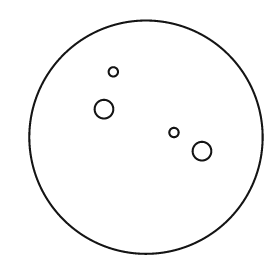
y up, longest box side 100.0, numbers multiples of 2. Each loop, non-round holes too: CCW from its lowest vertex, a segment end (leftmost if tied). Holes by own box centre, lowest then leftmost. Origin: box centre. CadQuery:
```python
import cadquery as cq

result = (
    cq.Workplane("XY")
    .moveTo(0.0, 0.0)
    .circle(50.0)
    .moveTo(24.0, -6.0)
    .circle(4.0)
    .moveTo(12.0, 2.0)
    .circle(2.0)
    .moveTo(-18.0, 12.0)
    .circle(4.0)
    .moveTo(-14.0, 28.0)
    .circle(2.0)
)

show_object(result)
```